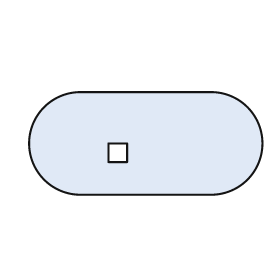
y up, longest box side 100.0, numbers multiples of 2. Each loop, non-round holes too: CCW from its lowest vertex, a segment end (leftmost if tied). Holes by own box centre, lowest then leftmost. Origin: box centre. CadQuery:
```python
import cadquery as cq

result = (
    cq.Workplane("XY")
    .moveTo(-28.0, -22.0)
    .lineTo(28.0, -22.0)
    .threePointArc((50.0, 0.0), (28.0, 22.0))
    .lineTo(-28.0, 22.0)
    .threePointArc((-50.0, 0.0), (-28.0, -22.0))
    .close()
    .moveTo(-16.0, -8.0)
    .lineTo(-8.0, -8.0)
    .lineTo(-8.0, 0.0)
    .lineTo(-16.0, 0.0)
    .close()
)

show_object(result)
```